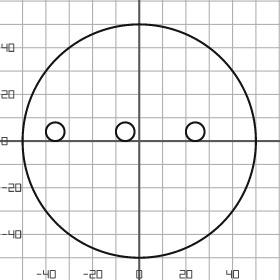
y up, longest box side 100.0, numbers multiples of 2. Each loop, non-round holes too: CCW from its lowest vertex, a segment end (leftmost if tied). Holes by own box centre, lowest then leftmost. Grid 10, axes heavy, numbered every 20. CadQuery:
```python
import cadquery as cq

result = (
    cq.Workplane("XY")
    .moveTo(0.0, 0.0)
    .circle(50.0)
    .moveTo(-36.0, 4.0)
    .circle(4.0)
    .moveTo(-6.0, 4.0)
    .circle(4.0)
    .moveTo(24.0, 4.0)
    .circle(4.0)
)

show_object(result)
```